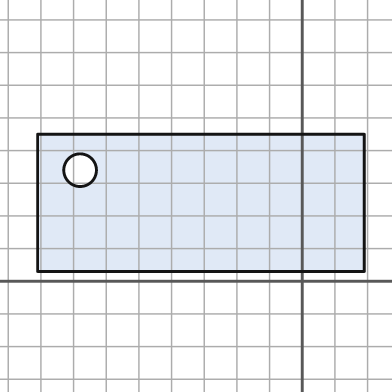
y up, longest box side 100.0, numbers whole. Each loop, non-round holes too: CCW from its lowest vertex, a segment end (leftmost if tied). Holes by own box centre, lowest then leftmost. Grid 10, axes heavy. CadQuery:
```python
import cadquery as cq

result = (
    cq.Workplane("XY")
    .moveTo(-81.0, 3.0)
    .lineTo(19.0, 3.0)
    .lineTo(19.0, 45.0)
    .lineTo(-81.0, 45.0)
    .close()
    .moveTo(-68.0, 34.0)
    .circle(5.0)
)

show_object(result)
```